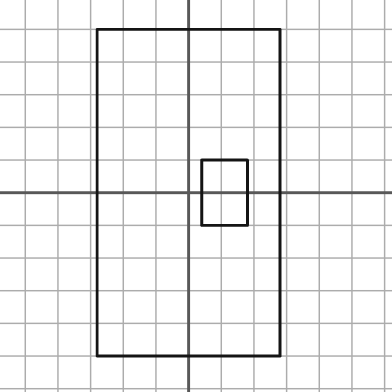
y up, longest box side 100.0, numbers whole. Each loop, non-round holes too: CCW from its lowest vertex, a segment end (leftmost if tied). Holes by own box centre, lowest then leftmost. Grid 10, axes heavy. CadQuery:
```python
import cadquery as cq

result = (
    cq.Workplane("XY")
    .moveTo(-28.0, -50.0)
    .lineTo(28.0, -50.0)
    .lineTo(28.0, 50.0)
    .lineTo(-28.0, 50.0)
    .close()
    .moveTo(4.0, -10.0)
    .lineTo(18.0, -10.0)
    .lineTo(18.0, 10.0)
    .lineTo(4.0, 10.0)
    .close()
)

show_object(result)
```